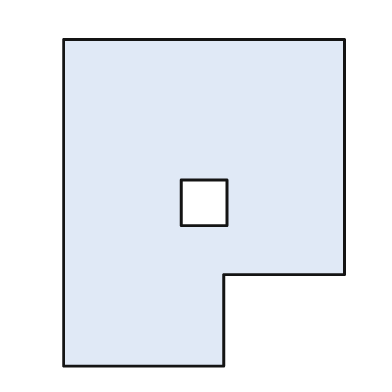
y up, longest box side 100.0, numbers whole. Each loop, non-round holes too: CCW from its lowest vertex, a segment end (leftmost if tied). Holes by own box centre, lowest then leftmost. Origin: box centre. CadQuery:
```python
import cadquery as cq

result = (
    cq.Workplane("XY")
    .moveTo(-43.0, -50.0)
    .lineTo(6.0, -50.0)
    .lineTo(6.0, -22.0)
    .lineTo(43.0, -22.0)
    .lineTo(43.0, 50.0)
    .lineTo(-43.0, 50.0)
    .close()
    .moveTo(-7.0, -7.0)
    .lineTo(7.0, -7.0)
    .lineTo(7.0, 7.0)
    .lineTo(-7.0, 7.0)
    .close()
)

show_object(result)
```